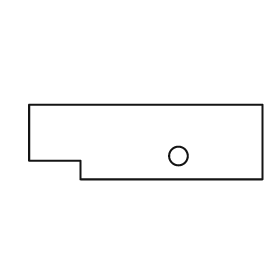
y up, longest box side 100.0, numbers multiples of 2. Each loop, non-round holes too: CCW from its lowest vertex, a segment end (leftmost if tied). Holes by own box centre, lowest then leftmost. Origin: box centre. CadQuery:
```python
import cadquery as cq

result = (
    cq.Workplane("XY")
    .moveTo(-28.0, -16.0)
    .lineTo(50.0, -16.0)
    .lineTo(50.0, 16.0)
    .lineTo(-50.0, 16.0)
    .lineTo(-50.0, -8.0)
    .lineTo(-28.0, -8.0)
    .close()
    .moveTo(14.0, -6.0)
    .circle(4.0)
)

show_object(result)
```